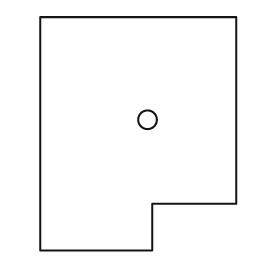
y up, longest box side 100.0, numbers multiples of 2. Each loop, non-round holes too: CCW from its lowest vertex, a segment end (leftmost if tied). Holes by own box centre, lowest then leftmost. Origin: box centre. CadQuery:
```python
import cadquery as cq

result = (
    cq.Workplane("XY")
    .moveTo(-42.0, -50.0)
    .lineTo(6.0, -50.0)
    .lineTo(6.0, -30.0)
    .lineTo(42.0, -30.0)
    .lineTo(42.0, 50.0)
    .lineTo(-42.0, 50.0)
    .close()
    .moveTo(4.0, 6.0)
    .circle(4.0)
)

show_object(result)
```